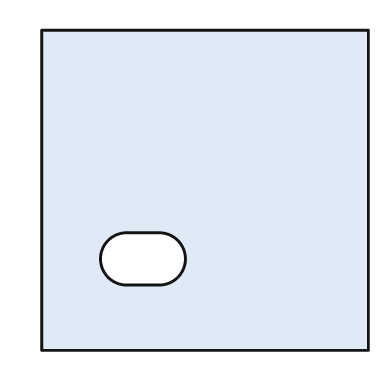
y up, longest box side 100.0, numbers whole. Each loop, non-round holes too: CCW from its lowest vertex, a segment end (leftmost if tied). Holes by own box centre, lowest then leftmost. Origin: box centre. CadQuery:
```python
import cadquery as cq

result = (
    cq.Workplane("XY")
    .moveTo(-50.0, -49.0)
    .lineTo(50.0, -49.0)
    .lineTo(50.0, 49.0)
    .lineTo(-50.0, 49.0)
    .close()
    .moveTo(-24.0, -29.0)
    .lineTo(-14.0, -29.0)
    .threePointArc((-6.0, -21.0), (-14.0, -13.0))
    .lineTo(-24.0, -13.0)
    .threePointArc((-32.0, -21.0), (-24.0, -29.0))
    .close()
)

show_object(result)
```